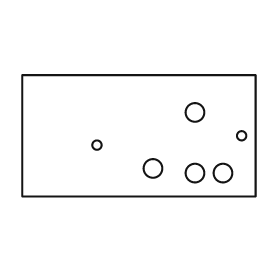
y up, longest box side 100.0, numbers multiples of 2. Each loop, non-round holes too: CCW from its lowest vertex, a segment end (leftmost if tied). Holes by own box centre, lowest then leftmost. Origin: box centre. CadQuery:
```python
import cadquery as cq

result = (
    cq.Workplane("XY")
    .moveTo(-50.0, -26.0)
    .lineTo(50.0, -26.0)
    .lineTo(50.0, 26.0)
    .lineTo(-50.0, 26.0)
    .close()
    .moveTo(24.0, -16.0)
    .circle(4.0)
    .moveTo(36.0, -16.0)
    .circle(4.0)
    .moveTo(6.0, -14.0)
    .circle(4.0)
    .moveTo(-18.0, -4.0)
    .circle(2.0)
    .moveTo(44.0, 0.0)
    .circle(2.0)
    .moveTo(24.0, 10.0)
    .circle(4.0)
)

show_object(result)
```